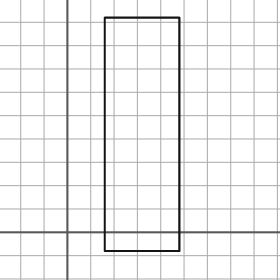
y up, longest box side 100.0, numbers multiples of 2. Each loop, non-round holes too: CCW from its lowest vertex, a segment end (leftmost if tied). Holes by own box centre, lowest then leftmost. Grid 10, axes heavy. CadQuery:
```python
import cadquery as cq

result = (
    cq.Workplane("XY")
    .moveTo(16.0, -8.0)
    .lineTo(48.0, -8.0)
    .lineTo(48.0, 92.0)
    .lineTo(16.0, 92.0)
    .close()
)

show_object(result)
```